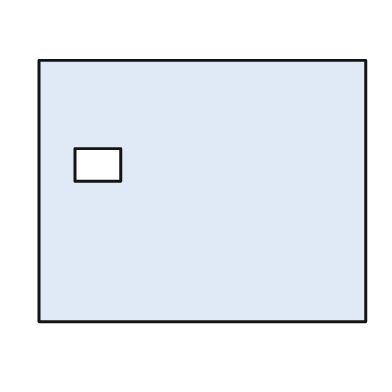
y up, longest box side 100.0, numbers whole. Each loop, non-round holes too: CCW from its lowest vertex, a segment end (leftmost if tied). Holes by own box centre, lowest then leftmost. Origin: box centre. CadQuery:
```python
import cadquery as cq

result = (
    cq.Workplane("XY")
    .moveTo(-50.0, -40.0)
    .lineTo(50.0, -40.0)
    .lineTo(50.0, 40.0)
    .lineTo(-50.0, 40.0)
    .close()
    .moveTo(-39.0, 3.0)
    .lineTo(-25.0, 3.0)
    .lineTo(-25.0, 13.0)
    .lineTo(-39.0, 13.0)
    .close()
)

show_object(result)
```